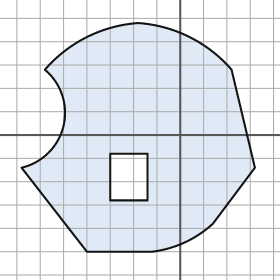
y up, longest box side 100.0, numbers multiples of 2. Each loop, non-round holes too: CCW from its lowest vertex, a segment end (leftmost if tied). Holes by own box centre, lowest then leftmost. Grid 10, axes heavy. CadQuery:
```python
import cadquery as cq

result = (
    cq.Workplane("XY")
    .moveTo(-40.0, -50.0)
    .lineTo(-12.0, -50.0)
    .threePointArc((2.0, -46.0), (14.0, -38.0))
    .lineTo(32.0, -14.0)
    .lineTo(22.0, 28.0)
    .threePointArc((4.0, 42.0), (-18.0, 48.0))
    .threePointArc((-40.0, 42.0), (-58.0, 28.0))
    .threePointArc((-50.0, 4.0), (-68.0, -14.0))
    .close()
    .moveTo(-30.0, -28.0)
    .lineTo(-14.0, -28.0)
    .lineTo(-14.0, -8.0)
    .lineTo(-30.0, -8.0)
    .close()
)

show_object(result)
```